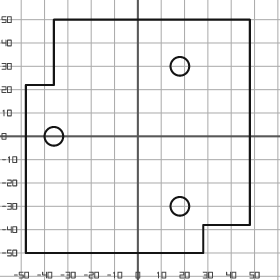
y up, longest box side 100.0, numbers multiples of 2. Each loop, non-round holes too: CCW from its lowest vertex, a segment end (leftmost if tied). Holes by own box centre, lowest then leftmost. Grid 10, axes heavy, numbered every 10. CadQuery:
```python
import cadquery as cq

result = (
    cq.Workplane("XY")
    .moveTo(-48.0, -50.0)
    .lineTo(28.0, -50.0)
    .lineTo(28.0, -38.0)
    .lineTo(48.0, -38.0)
    .lineTo(48.0, 50.0)
    .lineTo(-36.0, 50.0)
    .lineTo(-36.0, 22.0)
    .lineTo(-48.0, 22.0)
    .close()
    .moveTo(18.0, -30.0)
    .circle(4.0)
    .moveTo(-36.0, 0.0)
    .circle(4.0)
    .moveTo(18.0, 30.0)
    .circle(4.0)
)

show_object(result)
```